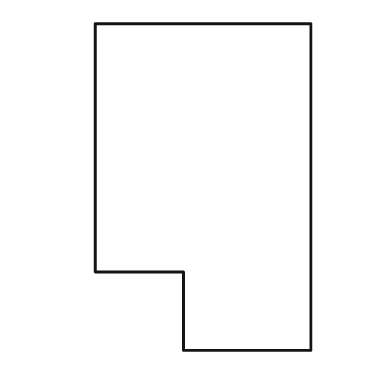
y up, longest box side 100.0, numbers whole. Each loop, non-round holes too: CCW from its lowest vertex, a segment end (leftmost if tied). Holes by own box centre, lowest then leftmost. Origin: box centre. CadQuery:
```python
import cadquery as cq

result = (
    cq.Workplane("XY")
    .moveTo(-6.0, -50.0)
    .lineTo(33.0, -50.0)
    .lineTo(33.0, 50.0)
    .lineTo(-33.0, 50.0)
    .lineTo(-33.0, -26.0)
    .lineTo(-6.0, -26.0)
    .close()
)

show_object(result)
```